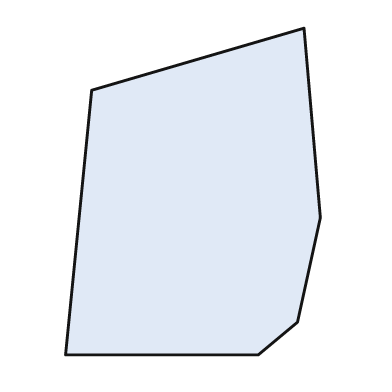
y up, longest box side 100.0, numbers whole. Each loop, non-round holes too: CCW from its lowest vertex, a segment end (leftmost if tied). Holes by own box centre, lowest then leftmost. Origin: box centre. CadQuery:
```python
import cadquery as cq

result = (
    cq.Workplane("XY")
    .moveTo(-39.0, -50.0)
    .lineTo(20.0, -50.0)
    .lineTo(32.0, -40.0)
    .lineTo(39.0, -8.0)
    .lineTo(34.0, 50.0)
    .lineTo(-31.0, 31.0)
    .close()
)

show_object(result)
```